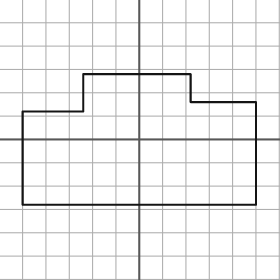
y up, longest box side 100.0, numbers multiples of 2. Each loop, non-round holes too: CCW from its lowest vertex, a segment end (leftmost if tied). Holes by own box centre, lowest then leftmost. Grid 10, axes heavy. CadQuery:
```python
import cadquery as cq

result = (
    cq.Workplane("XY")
    .moveTo(-50.0, -28.0)
    .lineTo(50.0, -28.0)
    .lineTo(50.0, 16.0)
    .lineTo(22.0, 16.0)
    .lineTo(22.0, 28.0)
    .lineTo(-24.0, 28.0)
    .lineTo(-24.0, 12.0)
    .lineTo(-50.0, 12.0)
    .close()
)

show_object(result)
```